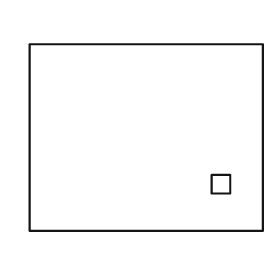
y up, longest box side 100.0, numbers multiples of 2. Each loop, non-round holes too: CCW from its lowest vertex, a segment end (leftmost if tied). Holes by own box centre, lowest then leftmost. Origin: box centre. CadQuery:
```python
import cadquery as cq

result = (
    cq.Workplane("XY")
    .moveTo(-50.0, -40.0)
    .lineTo(50.0, -40.0)
    .lineTo(50.0, 40.0)
    .lineTo(-50.0, 40.0)
    .close()
    .moveTo(28.0, -24.0)
    .lineTo(36.0, -24.0)
    .lineTo(36.0, -16.0)
    .lineTo(28.0, -16.0)
    .close()
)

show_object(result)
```